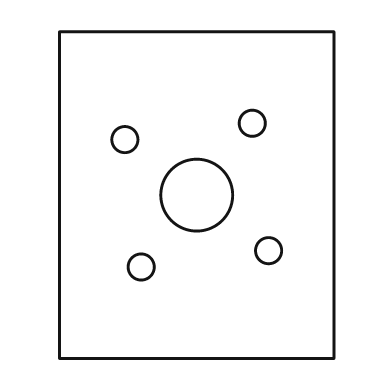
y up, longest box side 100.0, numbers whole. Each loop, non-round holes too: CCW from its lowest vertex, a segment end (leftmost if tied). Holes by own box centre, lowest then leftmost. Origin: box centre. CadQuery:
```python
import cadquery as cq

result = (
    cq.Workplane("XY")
    .moveTo(-42.0, -50.0)
    .lineTo(42.0, -50.0)
    .lineTo(42.0, 50.0)
    .lineTo(-42.0, 50.0)
    .close()
    .moveTo(-17.0, -22.0)
    .circle(4.0)
    .moveTo(22.0, -17.0)
    .circle(4.0)
    .moveTo(0.0, 0.0)
    .circle(11.0)
    .moveTo(-22.0, 17.0)
    .circle(4.0)
    .moveTo(17.0, 22.0)
    .circle(4.0)
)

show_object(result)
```